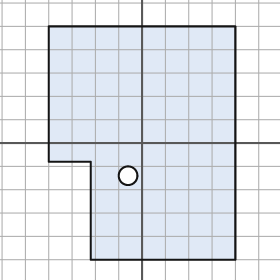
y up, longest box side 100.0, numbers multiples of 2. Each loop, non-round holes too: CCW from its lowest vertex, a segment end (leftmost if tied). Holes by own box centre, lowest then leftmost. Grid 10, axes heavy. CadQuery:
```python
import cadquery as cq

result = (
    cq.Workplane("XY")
    .moveTo(-22.0, -50.0)
    .lineTo(40.0, -50.0)
    .lineTo(40.0, 50.0)
    .lineTo(-40.0, 50.0)
    .lineTo(-40.0, -8.0)
    .lineTo(-22.0, -8.0)
    .close()
    .moveTo(-6.0, -14.0)
    .circle(4.0)
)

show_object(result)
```